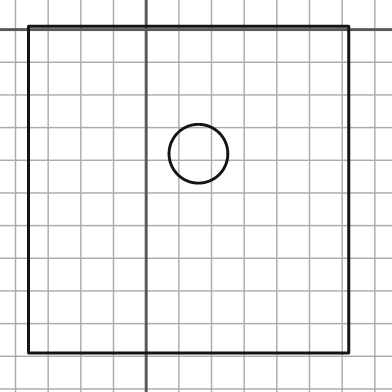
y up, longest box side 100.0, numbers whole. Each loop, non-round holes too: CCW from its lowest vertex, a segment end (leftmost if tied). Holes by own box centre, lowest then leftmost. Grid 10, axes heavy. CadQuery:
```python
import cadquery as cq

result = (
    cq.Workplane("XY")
    .moveTo(-36.0, -99.0)
    .lineTo(62.0, -99.0)
    .lineTo(62.0, 1.0)
    .lineTo(-36.0, 1.0)
    .close()
    .moveTo(16.0, -38.0)
    .circle(9.0)
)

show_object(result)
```